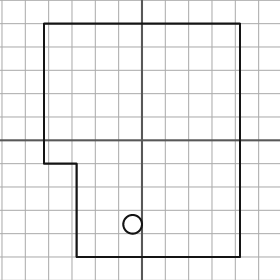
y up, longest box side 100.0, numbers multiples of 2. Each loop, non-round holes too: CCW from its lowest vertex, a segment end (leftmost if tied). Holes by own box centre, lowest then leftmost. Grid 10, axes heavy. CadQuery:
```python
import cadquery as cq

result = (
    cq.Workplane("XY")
    .moveTo(-28.0, -50.0)
    .lineTo(42.0, -50.0)
    .lineTo(42.0, 50.0)
    .lineTo(-42.0, 50.0)
    .lineTo(-42.0, -10.0)
    .lineTo(-28.0, -10.0)
    .close()
    .moveTo(-4.0, -36.0)
    .circle(4.0)
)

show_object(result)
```